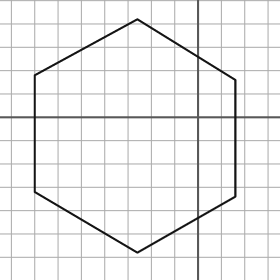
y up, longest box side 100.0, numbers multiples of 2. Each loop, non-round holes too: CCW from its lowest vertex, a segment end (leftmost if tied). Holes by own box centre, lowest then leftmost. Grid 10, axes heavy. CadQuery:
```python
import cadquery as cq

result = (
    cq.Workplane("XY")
    .moveTo(-26.0, -58.0)
    .lineTo(16.0, -34.0)
    .lineTo(16.0, 16.0)
    .lineTo(-26.0, 42.0)
    .lineTo(-70.0, 18.0)
    .lineTo(-70.0, -32.0)
    .close()
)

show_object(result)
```